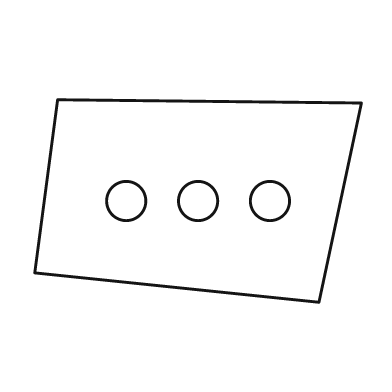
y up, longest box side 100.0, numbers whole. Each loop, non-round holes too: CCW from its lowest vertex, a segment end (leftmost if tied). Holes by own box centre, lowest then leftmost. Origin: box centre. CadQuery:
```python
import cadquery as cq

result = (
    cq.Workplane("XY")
    .moveTo(37.0, -31.0)
    .lineTo(50.0, 30.0)
    .lineTo(-43.0, 31.0)
    .lineTo(-50.0, -22.0)
    .close()
    .moveTo(-22.0, 0.0)
    .circle(6.0)
    .moveTo(0.0, 0.0)
    .circle(6.0)
    .moveTo(22.0, 0.0)
    .circle(6.0)
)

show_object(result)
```